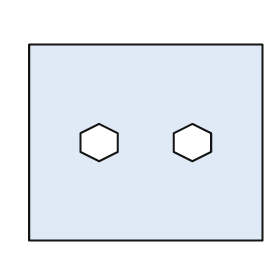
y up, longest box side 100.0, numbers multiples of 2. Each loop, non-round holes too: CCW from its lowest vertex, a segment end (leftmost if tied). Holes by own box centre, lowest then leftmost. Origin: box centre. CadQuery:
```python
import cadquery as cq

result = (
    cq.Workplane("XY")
    .moveTo(-50.0, -42.0)
    .lineTo(50.0, -42.0)
    .lineTo(50.0, 42.0)
    .lineTo(-50.0, 42.0)
    .close()
    .moveTo(-20.0, -8.0)
    .lineTo(-12.0, -4.0)
    .lineTo(-12.0, 4.0)
    .lineTo(-20.0, 8.0)
    .lineTo(-28.0, 4.0)
    .lineTo(-28.0, -4.0)
    .close()
    .moveTo(20.0, -8.0)
    .lineTo(28.0, -4.0)
    .lineTo(28.0, 4.0)
    .lineTo(20.0, 8.0)
    .lineTo(12.0, 4.0)
    .lineTo(12.0, -4.0)
    .close()
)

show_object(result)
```